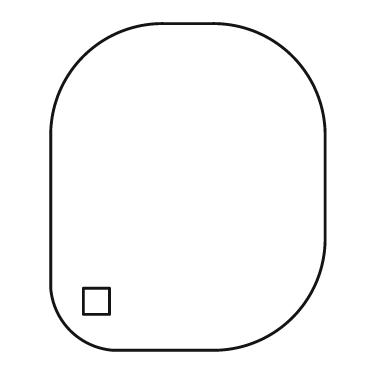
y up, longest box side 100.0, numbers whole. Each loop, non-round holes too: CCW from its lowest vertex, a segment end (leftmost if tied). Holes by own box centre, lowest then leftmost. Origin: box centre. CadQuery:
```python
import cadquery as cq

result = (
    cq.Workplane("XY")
    .moveTo(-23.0, -50.0)
    .lineTo(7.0, -50.0)
    .threePointArc((32.0, -40.0), (42.0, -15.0))
    .lineTo(42.0, 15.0)
    .threePointArc((32.0, 40.0), (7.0, 50.0))
    .lineTo(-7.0, 50.0)
    .threePointArc((-32.0, 40.0), (-42.0, 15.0))
    .lineTo(-42.0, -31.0)
    .threePointArc((-36.0, -44.0), (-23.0, -50.0))
    .close()
    .moveTo(-32.0, -39.0)
    .lineTo(-24.0, -39.0)
    .lineTo(-24.0, -31.0)
    .lineTo(-32.0, -31.0)
    .close()
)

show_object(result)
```